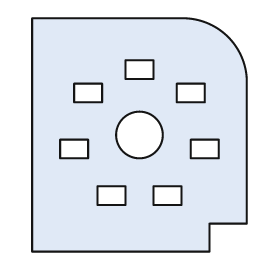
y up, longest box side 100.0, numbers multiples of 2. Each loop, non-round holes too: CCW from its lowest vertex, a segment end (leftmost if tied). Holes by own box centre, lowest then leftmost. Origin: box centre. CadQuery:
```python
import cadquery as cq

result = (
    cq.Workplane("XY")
    .moveTo(-46.0, -50.0)
    .lineTo(30.0, -50.0)
    .lineTo(30.0, -38.0)
    .lineTo(46.0, -38.0)
    .lineTo(46.0, 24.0)
    .threePointArc((38.0, 42.0), (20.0, 50.0))
    .lineTo(-46.0, 50.0)
    .close()
    .moveTo(-18.0, -30.0)
    .lineTo(-6.0, -30.0)
    .lineTo(-6.0, -22.0)
    .lineTo(-18.0, -22.0)
    .close()
    .moveTo(6.0, -30.0)
    .lineTo(18.0, -30.0)
    .lineTo(18.0, -22.0)
    .lineTo(6.0, -22.0)
    .close()
    .moveTo(-34.0, -10.0)
    .lineTo(-22.0, -10.0)
    .lineTo(-22.0, -2.0)
    .lineTo(-34.0, -2.0)
    .close()
    .moveTo(22.0, -10.0)
    .lineTo(34.0, -10.0)
    .lineTo(34.0, -2.0)
    .lineTo(22.0, -2.0)
    .close()
    .moveTo(0.0, 0.0)
    .circle(10.0)
    .moveTo(-28.0, 14.0)
    .lineTo(-16.0, 14.0)
    .lineTo(-16.0, 22.0)
    .lineTo(-28.0, 22.0)
    .close()
    .moveTo(16.0, 14.0)
    .lineTo(28.0, 14.0)
    .lineTo(28.0, 22.0)
    .lineTo(16.0, 22.0)
    .close()
    .moveTo(-6.0, 24.0)
    .lineTo(6.0, 24.0)
    .lineTo(6.0, 32.0)
    .lineTo(-6.0, 32.0)
    .close()
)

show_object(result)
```